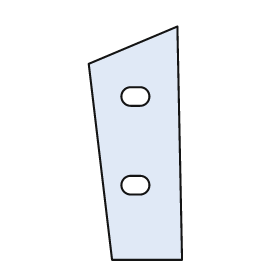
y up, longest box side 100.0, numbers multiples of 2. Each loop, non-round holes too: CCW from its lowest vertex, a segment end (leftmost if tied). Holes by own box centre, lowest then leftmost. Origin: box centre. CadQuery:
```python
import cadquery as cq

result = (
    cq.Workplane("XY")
    .moveTo(-10.0, -50.0)
    .lineTo(20.0, -50.0)
    .lineTo(18.0, 50.0)
    .lineTo(-20.0, 34.0)
    .close()
    .moveTo(-2.0, -22.0)
    .lineTo(2.0, -22.0)
    .threePointArc((6.0, -18.0), (2.0, -14.0))
    .lineTo(-2.0, -14.0)
    .threePointArc((-6.0, -18.0), (-2.0, -22.0))
    .close()
    .moveTo(-2.0, 16.0)
    .lineTo(2.0, 16.0)
    .threePointArc((6.0, 20.0), (2.0, 24.0))
    .lineTo(-2.0, 24.0)
    .threePointArc((-6.0, 20.0), (-2.0, 16.0))
    .close()
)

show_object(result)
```